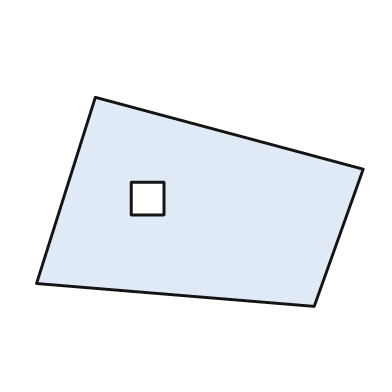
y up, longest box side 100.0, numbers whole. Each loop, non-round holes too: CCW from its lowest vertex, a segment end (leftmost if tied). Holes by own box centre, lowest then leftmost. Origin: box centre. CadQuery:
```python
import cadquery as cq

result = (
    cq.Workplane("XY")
    .moveTo(35.0, -32.0)
    .lineTo(50.0, 10.0)
    .lineTo(-32.0, 32.0)
    .lineTo(-50.0, -25.0)
    .close()
    .moveTo(-21.0, -4.0)
    .lineTo(-11.0, -4.0)
    .lineTo(-11.0, 6.0)
    .lineTo(-21.0, 6.0)
    .close()
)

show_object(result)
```